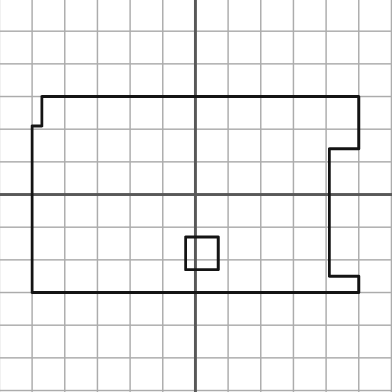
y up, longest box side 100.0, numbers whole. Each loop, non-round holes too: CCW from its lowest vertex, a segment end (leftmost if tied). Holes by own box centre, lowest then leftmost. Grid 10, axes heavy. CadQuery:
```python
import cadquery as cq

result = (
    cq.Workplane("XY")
    .moveTo(-50.0, -30.0)
    .lineTo(50.0, -30.0)
    .lineTo(50.0, -25.0)
    .lineTo(41.0, -25.0)
    .lineTo(41.0, 14.0)
    .lineTo(50.0, 14.0)
    .lineTo(50.0, 30.0)
    .lineTo(-47.0, 30.0)
    .lineTo(-47.0, 21.0)
    .lineTo(-50.0, 21.0)
    .close()
    .moveTo(-3.0, -23.0)
    .lineTo(7.0, -23.0)
    .lineTo(7.0, -13.0)
    .lineTo(-3.0, -13.0)
    .close()
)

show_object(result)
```